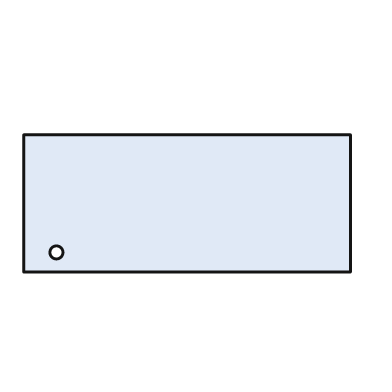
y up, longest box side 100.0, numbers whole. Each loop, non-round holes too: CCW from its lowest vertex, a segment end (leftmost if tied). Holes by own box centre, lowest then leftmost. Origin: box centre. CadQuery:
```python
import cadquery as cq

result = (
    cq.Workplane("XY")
    .moveTo(-50.0, -21.0)
    .lineTo(50.0, -21.0)
    .lineTo(50.0, 21.0)
    .lineTo(-50.0, 21.0)
    .close()
    .moveTo(-40.0, -15.0)
    .circle(2.0)
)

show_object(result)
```